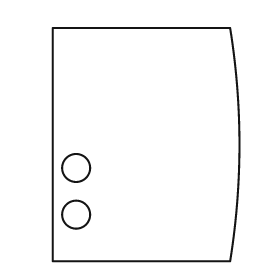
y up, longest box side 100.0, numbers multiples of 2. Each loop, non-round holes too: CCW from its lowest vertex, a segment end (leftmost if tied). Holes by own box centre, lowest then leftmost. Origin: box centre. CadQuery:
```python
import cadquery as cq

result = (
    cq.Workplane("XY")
    .moveTo(-40.0, -50.0)
    .lineTo(36.0, -50.0)
    .threePointArc((40.0, 0.0), (36.0, 50.0))
    .lineTo(-40.0, 50.0)
    .close()
    .moveTo(-30.0, -30.0)
    .circle(6.0)
    .moveTo(-30.0, -10.0)
    .circle(6.0)
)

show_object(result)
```